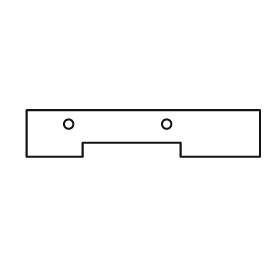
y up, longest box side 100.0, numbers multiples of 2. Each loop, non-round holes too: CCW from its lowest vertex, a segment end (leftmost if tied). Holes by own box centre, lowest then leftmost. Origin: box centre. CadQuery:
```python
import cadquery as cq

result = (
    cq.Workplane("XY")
    .moveTo(-50.0, -10.0)
    .lineTo(-26.0, -10.0)
    .lineTo(-26.0, -4.0)
    .lineTo(16.0, -4.0)
    .lineTo(16.0, -10.0)
    .lineTo(50.0, -10.0)
    .lineTo(50.0, 10.0)
    .lineTo(-50.0, 10.0)
    .close()
    .moveTo(-32.0, 4.0)
    .circle(2.0)
    .moveTo(10.0, 4.0)
    .circle(2.0)
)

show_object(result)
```